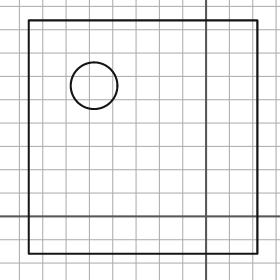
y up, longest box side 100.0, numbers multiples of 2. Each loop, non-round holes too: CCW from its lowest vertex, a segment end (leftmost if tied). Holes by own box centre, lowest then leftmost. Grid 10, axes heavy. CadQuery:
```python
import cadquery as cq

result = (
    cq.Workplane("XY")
    .moveTo(-76.0, -16.0)
    .lineTo(22.0, -16.0)
    .lineTo(22.0, 84.0)
    .lineTo(-76.0, 84.0)
    .close()
    .moveTo(-48.0, 56.0)
    .circle(10.0)
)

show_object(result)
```